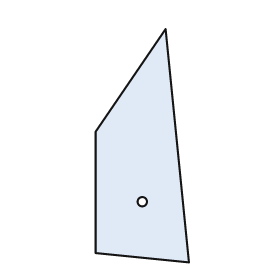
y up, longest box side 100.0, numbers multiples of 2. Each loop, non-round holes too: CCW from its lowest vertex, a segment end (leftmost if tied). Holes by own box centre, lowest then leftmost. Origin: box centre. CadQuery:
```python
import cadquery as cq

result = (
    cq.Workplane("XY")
    .moveTo(20.0, -50.0)
    .lineTo(10.0, 50.0)
    .lineTo(-20.0, 6.0)
    .lineTo(-20.0, -46.0)
    .close()
    .moveTo(0.0, -24.0)
    .circle(2.0)
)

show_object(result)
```